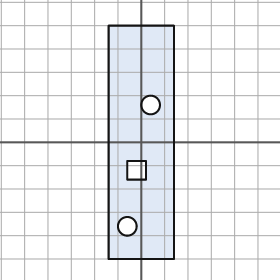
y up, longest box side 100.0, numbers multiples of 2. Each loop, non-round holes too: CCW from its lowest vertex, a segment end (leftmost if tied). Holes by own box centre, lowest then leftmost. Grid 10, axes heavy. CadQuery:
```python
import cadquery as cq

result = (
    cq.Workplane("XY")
    .moveTo(-14.0, -50.0)
    .lineTo(14.0, -50.0)
    .lineTo(14.0, 50.0)
    .lineTo(-14.0, 50.0)
    .close()
    .moveTo(-6.0, -36.0)
    .circle(4.0)
    .moveTo(-6.0, -16.0)
    .lineTo(2.0, -16.0)
    .lineTo(2.0, -8.0)
    .lineTo(-6.0, -8.0)
    .close()
    .moveTo(4.0, 16.0)
    .circle(4.0)
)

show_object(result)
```